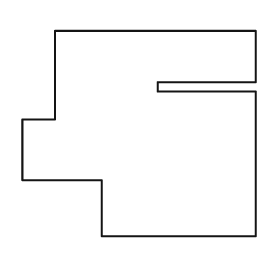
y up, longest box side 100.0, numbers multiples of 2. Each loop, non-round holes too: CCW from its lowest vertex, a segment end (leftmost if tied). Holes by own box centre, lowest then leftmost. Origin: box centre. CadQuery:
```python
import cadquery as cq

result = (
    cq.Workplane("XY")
    .moveTo(-16.0, -44.0)
    .lineTo(50.0, -44.0)
    .lineTo(50.0, 18.0)
    .lineTo(8.0, 18.0)
    .lineTo(8.0, 22.0)
    .lineTo(50.0, 22.0)
    .lineTo(50.0, 44.0)
    .lineTo(-36.0, 44.0)
    .lineTo(-36.0, 6.0)
    .lineTo(-50.0, 6.0)
    .lineTo(-50.0, -20.0)
    .lineTo(-16.0, -20.0)
    .close()
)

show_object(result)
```